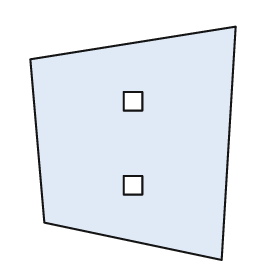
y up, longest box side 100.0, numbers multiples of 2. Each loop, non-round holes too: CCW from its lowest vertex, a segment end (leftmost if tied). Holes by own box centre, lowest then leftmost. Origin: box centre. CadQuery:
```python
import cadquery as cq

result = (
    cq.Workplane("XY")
    .moveTo(38.0, -50.0)
    .lineTo(44.0, 50.0)
    .lineTo(-44.0, 36.0)
    .lineTo(-38.0, -34.0)
    .close()
    .moveTo(-4.0, -22.0)
    .lineTo(4.0, -22.0)
    .lineTo(4.0, -14.0)
    .lineTo(-4.0, -14.0)
    .close()
    .moveTo(-4.0, 14.0)
    .lineTo(4.0, 14.0)
    .lineTo(4.0, 22.0)
    .lineTo(-4.0, 22.0)
    .close()
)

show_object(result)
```